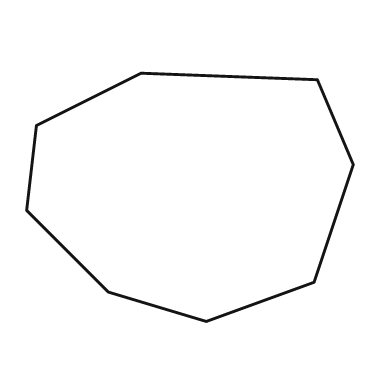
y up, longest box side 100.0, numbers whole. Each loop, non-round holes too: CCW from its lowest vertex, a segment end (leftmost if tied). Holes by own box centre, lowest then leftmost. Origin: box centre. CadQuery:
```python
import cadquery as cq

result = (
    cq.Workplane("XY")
    .moveTo(5.0, -38.0)
    .lineTo(38.0, -26.0)
    .lineTo(50.0, 10.0)
    .lineTo(39.0, 36.0)
    .lineTo(-15.0, 38.0)
    .lineTo(-47.0, 22.0)
    .lineTo(-50.0, -4.0)
    .lineTo(-25.0, -29.0)
    .close()
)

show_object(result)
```